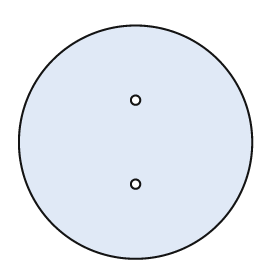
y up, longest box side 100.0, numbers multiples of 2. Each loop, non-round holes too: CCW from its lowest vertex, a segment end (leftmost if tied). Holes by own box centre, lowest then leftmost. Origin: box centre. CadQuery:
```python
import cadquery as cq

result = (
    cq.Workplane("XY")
    .moveTo(0.0, 0.0)
    .circle(50.0)
    .moveTo(0.0, -18.0)
    .circle(2.0)
    .moveTo(0.0, 18.0)
    .circle(2.0)
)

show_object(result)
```